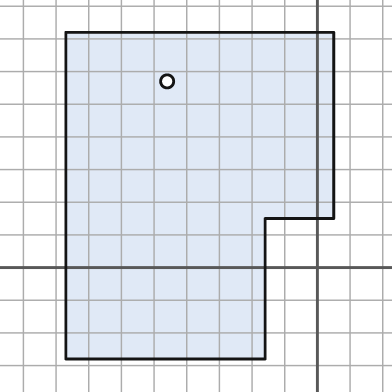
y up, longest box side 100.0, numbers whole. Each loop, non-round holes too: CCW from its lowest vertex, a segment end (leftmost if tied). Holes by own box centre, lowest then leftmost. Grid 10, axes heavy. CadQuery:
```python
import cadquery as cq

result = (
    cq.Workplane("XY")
    .moveTo(-77.0, -28.0)
    .lineTo(-16.0, -28.0)
    .lineTo(-16.0, 15.0)
    .lineTo(5.0, 15.0)
    .lineTo(5.0, 72.0)
    .lineTo(-77.0, 72.0)
    .close()
    .moveTo(-46.0, 57.0)
    .circle(2.0)
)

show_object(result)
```